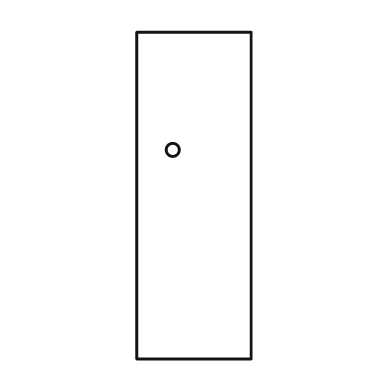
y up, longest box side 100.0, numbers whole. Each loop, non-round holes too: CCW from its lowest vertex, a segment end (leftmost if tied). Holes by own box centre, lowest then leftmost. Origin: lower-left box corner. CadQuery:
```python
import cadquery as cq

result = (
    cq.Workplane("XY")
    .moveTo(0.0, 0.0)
    .lineTo(35.0, 0.0)
    .lineTo(35.0, 100.0)
    .lineTo(0.0, 100.0)
    .close()
    .moveTo(11.0, 64.0)
    .circle(2.0)
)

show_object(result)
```